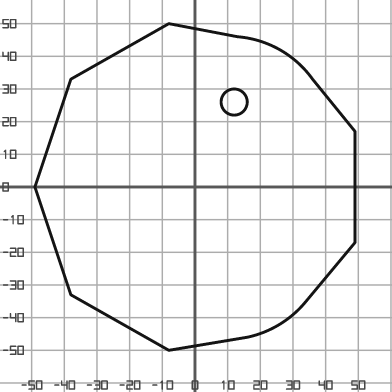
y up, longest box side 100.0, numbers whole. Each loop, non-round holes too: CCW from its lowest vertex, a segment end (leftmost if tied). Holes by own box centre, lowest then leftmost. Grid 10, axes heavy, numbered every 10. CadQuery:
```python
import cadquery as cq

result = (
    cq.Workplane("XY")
    .moveTo(-8.0, -50.0)
    .lineTo(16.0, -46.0)
    .threePointArc((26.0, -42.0), (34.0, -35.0))
    .lineTo(49.0, -17.0)
    .lineTo(49.0, 17.0)
    .lineTo(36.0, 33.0)
    .threePointArc((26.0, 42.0), (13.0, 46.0))
    .lineTo(-8.0, 50.0)
    .lineTo(-38.0, 33.0)
    .lineTo(-49.0, 0.0)
    .lineTo(-38.0, -33.0)
    .close()
    .moveTo(12.0, 26.0)
    .circle(4.0)
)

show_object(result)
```